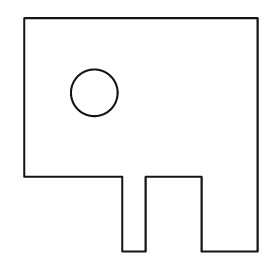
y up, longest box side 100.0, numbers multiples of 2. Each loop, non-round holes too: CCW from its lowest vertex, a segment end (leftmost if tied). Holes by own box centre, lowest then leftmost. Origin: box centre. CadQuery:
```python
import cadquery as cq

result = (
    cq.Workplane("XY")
    .moveTo(-8.0, -50.0)
    .lineTo(2.0, -50.0)
    .lineTo(2.0, -18.0)
    .lineTo(26.0, -18.0)
    .lineTo(26.0, -50.0)
    .lineTo(50.0, -50.0)
    .lineTo(50.0, 50.0)
    .lineTo(-50.0, 50.0)
    .lineTo(-50.0, -18.0)
    .lineTo(-8.0, -18.0)
    .close()
    .moveTo(-20.0, 18.0)
    .circle(10.0)
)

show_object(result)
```